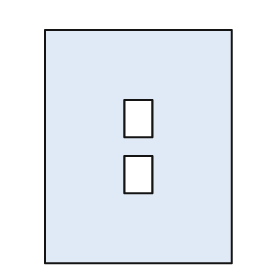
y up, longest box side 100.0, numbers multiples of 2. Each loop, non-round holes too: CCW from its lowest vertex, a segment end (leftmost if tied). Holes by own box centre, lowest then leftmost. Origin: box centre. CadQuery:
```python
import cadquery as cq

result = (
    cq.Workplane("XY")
    .moveTo(-40.0, -50.0)
    .lineTo(40.0, -50.0)
    .lineTo(40.0, 50.0)
    .lineTo(-40.0, 50.0)
    .close()
    .moveTo(-6.0, -20.0)
    .lineTo(6.0, -20.0)
    .lineTo(6.0, -4.0)
    .lineTo(-6.0, -4.0)
    .close()
    .moveTo(-6.0, 4.0)
    .lineTo(6.0, 4.0)
    .lineTo(6.0, 20.0)
    .lineTo(-6.0, 20.0)
    .close()
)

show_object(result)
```